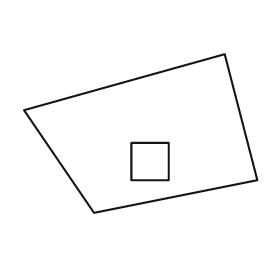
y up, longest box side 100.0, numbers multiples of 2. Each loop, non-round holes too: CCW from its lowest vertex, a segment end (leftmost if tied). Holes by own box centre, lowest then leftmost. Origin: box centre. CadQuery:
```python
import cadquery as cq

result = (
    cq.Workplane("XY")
    .moveTo(-20.0, -34.0)
    .lineTo(50.0, -20.0)
    .lineTo(36.0, 34.0)
    .lineTo(-50.0, 10.0)
    .close()
    .moveTo(-4.0, -20.0)
    .lineTo(12.0, -20.0)
    .lineTo(12.0, -4.0)
    .lineTo(-4.0, -4.0)
    .close()
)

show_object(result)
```